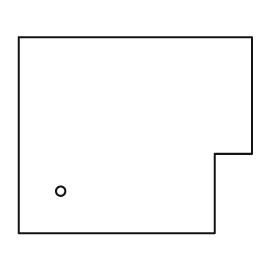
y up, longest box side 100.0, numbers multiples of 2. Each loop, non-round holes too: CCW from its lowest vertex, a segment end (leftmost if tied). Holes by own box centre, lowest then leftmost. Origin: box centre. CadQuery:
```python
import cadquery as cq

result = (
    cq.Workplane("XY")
    .moveTo(-50.0, -42.0)
    .lineTo(34.0, -42.0)
    .lineTo(34.0, -8.0)
    .lineTo(50.0, -8.0)
    .lineTo(50.0, 42.0)
    .lineTo(-50.0, 42.0)
    .close()
    .moveTo(-32.0, -24.0)
    .circle(2.0)
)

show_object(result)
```